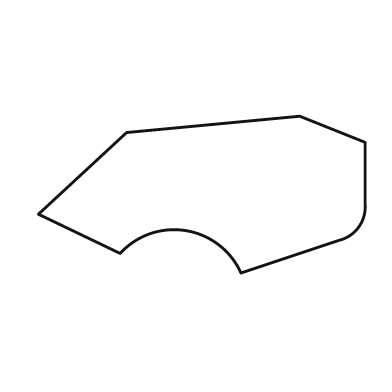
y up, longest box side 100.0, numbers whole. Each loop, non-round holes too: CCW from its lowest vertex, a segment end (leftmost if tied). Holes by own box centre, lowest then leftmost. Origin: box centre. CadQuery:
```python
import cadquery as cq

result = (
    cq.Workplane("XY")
    .moveTo(12.0, -24.0)
    .lineTo(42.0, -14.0)
    .threePointArc((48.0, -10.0), (50.0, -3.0))
    .lineTo(50.0, 16.0)
    .lineTo(30.0, 24.0)
    .lineTo(-23.0, 19.0)
    .lineTo(-50.0, -6.0)
    .lineTo(-25.0, -18.0)
    .threePointArc((-5.0, -11.0), (12.0, -24.0))
    .close()
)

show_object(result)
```